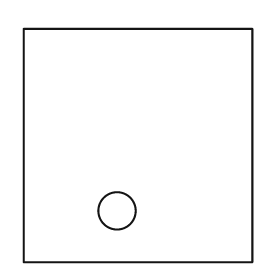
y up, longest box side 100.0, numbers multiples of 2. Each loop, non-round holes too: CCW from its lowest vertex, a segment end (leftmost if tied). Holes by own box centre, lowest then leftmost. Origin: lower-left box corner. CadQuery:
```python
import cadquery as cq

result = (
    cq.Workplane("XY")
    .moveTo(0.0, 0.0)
    .lineTo(98.0, 0.0)
    .lineTo(98.0, 100.0)
    .lineTo(0.0, 100.0)
    .close()
    .moveTo(40.0, 22.0)
    .circle(8.0)
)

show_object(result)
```